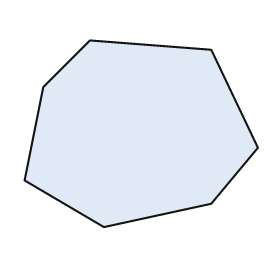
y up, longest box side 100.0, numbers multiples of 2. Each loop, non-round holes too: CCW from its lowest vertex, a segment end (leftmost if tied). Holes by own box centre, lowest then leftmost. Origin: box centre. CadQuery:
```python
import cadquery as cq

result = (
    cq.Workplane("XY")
    .moveTo(-16.0, -40.0)
    .lineTo(30.0, -30.0)
    .lineTo(50.0, -6.0)
    .lineTo(30.0, 36.0)
    .lineTo(-22.0, 40.0)
    .lineTo(-42.0, 20.0)
    .lineTo(-50.0, -20.0)
    .close()
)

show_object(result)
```